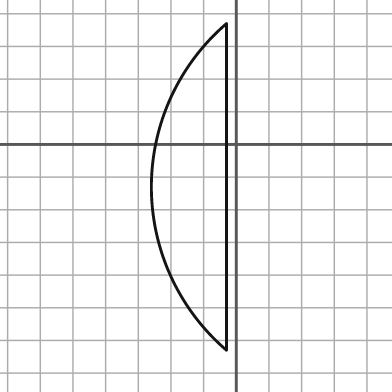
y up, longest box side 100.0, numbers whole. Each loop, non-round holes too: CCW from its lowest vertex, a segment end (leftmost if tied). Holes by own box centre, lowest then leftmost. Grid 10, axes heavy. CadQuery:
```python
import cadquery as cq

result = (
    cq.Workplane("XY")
    .moveTo(-3.0, -63.0)
    .lineTo(-3.0, 37.0)
    .threePointArc((-26.0, -13.0), (-3.0, -63.0))
    .close()
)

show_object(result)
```